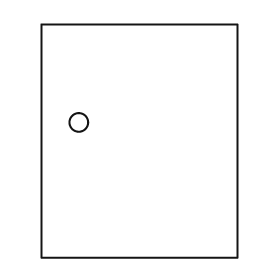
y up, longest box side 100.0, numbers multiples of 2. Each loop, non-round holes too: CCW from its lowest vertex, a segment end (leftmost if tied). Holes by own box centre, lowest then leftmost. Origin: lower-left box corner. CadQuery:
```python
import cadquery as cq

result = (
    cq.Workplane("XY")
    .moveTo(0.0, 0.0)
    .lineTo(84.0, 0.0)
    .lineTo(84.0, 100.0)
    .lineTo(0.0, 100.0)
    .close()
    .moveTo(16.0, 58.0)
    .circle(4.0)
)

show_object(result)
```